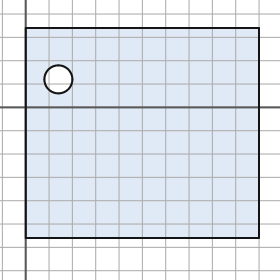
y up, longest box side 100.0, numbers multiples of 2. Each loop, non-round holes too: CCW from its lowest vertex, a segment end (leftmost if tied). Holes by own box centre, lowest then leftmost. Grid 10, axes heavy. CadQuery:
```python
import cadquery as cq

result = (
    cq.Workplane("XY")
    .moveTo(0.0, -56.0)
    .lineTo(100.0, -56.0)
    .lineTo(100.0, 34.0)
    .lineTo(0.0, 34.0)
    .close()
    .moveTo(14.0, 12.0)
    .circle(6.0)
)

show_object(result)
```